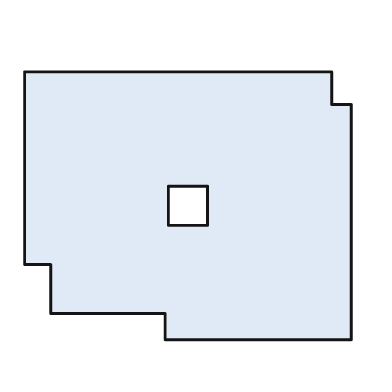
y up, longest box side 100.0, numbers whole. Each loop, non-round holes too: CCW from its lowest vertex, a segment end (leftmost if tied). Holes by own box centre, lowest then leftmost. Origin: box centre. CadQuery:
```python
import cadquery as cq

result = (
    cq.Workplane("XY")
    .moveTo(-7.0, -41.0)
    .lineTo(50.0, -41.0)
    .lineTo(50.0, 31.0)
    .lineTo(44.0, 31.0)
    .lineTo(44.0, 41.0)
    .lineTo(-50.0, 41.0)
    .lineTo(-50.0, -18.0)
    .lineTo(-42.0, -18.0)
    .lineTo(-42.0, -33.0)
    .lineTo(-7.0, -33.0)
    .close()
    .moveTo(-6.0, -6.0)
    .lineTo(6.0, -6.0)
    .lineTo(6.0, 6.0)
    .lineTo(-6.0, 6.0)
    .close()
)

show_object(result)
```